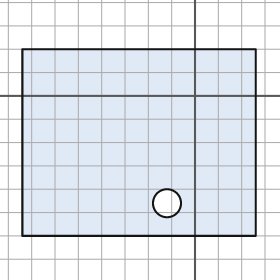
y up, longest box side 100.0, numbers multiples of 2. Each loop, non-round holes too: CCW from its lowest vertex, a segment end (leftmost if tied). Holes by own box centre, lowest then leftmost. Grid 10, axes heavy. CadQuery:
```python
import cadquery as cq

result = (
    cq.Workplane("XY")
    .moveTo(-74.0, -60.0)
    .lineTo(26.0, -60.0)
    .lineTo(26.0, 20.0)
    .lineTo(-74.0, 20.0)
    .close()
    .moveTo(-12.0, -46.0)
    .circle(6.0)
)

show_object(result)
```